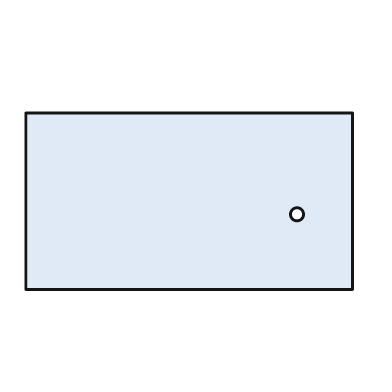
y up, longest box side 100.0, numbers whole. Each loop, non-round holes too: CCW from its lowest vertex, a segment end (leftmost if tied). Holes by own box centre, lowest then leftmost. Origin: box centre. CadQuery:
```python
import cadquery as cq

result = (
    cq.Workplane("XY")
    .moveTo(-50.0, -27.0)
    .lineTo(50.0, -27.0)
    .lineTo(50.0, 27.0)
    .lineTo(-50.0, 27.0)
    .close()
    .moveTo(33.0, -4.0)
    .circle(2.0)
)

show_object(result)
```